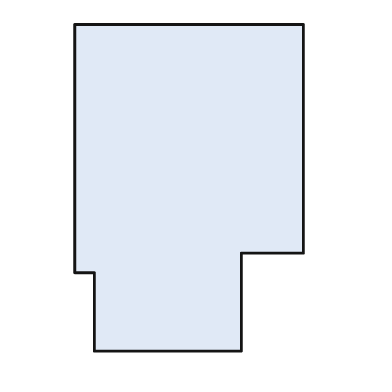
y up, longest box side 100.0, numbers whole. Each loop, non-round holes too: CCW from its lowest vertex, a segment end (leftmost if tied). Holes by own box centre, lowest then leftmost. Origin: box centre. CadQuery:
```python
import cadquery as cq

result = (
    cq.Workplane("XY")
    .moveTo(-29.0, -50.0)
    .lineTo(16.0, -50.0)
    .lineTo(16.0, -20.0)
    .lineTo(35.0, -20.0)
    .lineTo(35.0, 50.0)
    .lineTo(-35.0, 50.0)
    .lineTo(-35.0, -26.0)
    .lineTo(-29.0, -26.0)
    .close()
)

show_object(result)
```